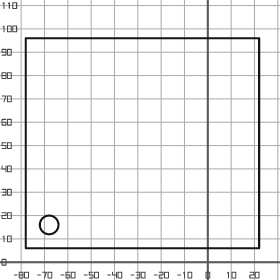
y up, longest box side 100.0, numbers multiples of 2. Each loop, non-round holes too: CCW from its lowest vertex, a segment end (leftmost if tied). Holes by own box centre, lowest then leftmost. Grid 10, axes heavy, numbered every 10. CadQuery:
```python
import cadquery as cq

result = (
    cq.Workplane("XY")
    .moveTo(-78.0, 6.0)
    .lineTo(22.0, 6.0)
    .lineTo(22.0, 96.0)
    .lineTo(-78.0, 96.0)
    .close()
    .moveTo(-68.0, 16.0)
    .circle(4.0)
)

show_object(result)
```